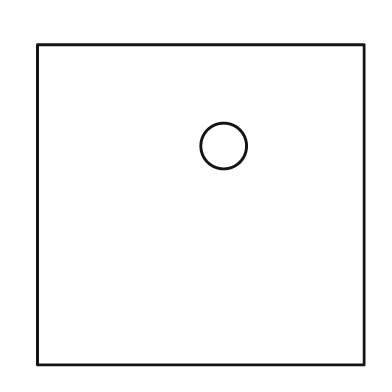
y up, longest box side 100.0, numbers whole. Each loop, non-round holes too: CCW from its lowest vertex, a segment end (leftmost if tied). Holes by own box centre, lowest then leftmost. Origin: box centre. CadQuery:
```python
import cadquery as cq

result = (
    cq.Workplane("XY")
    .moveTo(-50.0, -49.0)
    .lineTo(50.0, -49.0)
    .lineTo(50.0, 49.0)
    .lineTo(-50.0, 49.0)
    .close()
    .moveTo(7.0, 18.0)
    .circle(7.0)
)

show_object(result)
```